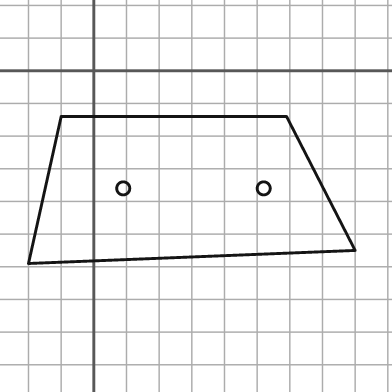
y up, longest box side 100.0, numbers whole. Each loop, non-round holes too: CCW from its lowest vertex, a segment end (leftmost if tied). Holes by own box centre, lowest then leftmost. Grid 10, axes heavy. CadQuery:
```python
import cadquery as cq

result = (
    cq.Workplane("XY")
    .moveTo(-20.0, -59.0)
    .lineTo(80.0, -55.0)
    .lineTo(59.0, -14.0)
    .lineTo(-10.0, -14.0)
    .close()
    .moveTo(9.0, -36.0)
    .circle(2.0)
    .moveTo(52.0, -36.0)
    .circle(2.0)
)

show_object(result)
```